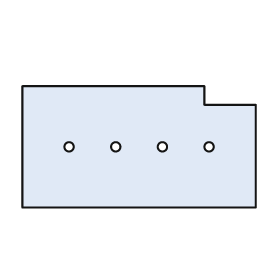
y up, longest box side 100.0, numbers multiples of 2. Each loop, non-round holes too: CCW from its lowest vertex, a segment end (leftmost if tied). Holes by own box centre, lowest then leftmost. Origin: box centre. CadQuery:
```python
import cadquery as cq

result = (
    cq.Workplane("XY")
    .moveTo(-50.0, -26.0)
    .lineTo(50.0, -26.0)
    .lineTo(50.0, 18.0)
    .lineTo(28.0, 18.0)
    .lineTo(28.0, 26.0)
    .lineTo(-50.0, 26.0)
    .close()
    .moveTo(-30.0, 0.0)
    .circle(2.0)
    .moveTo(-10.0, 0.0)
    .circle(2.0)
    .moveTo(10.0, 0.0)
    .circle(2.0)
    .moveTo(30.0, 0.0)
    .circle(2.0)
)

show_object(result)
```